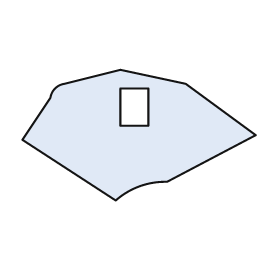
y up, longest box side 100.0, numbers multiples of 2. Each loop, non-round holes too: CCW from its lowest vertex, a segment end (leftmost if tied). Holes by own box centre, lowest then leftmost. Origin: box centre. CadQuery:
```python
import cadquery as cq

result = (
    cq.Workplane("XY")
    .moveTo(-10.0, -28.0)
    .threePointArc((0.0, -22.0), (12.0, -20.0))
    .lineTo(50.0, 0.0)
    .lineTo(20.0, 22.0)
    .lineTo(-8.0, 28.0)
    .lineTo(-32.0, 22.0)
    .threePointArc((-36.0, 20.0), (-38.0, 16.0))
    .lineTo(-50.0, -2.0)
    .close()
    .moveTo(-8.0, 4.0)
    .lineTo(4.0, 4.0)
    .lineTo(4.0, 20.0)
    .lineTo(-8.0, 20.0)
    .close()
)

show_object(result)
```